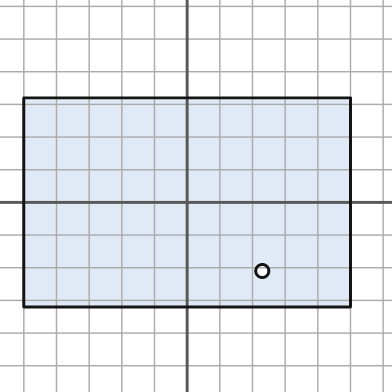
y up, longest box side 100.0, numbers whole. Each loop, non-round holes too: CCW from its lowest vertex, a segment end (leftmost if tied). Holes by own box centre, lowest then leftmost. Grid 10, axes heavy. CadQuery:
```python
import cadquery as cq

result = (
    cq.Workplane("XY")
    .moveTo(-50.0, -32.0)
    .lineTo(50.0, -32.0)
    .lineTo(50.0, 32.0)
    .lineTo(-50.0, 32.0)
    .close()
    .moveTo(23.0, -21.0)
    .circle(2.0)
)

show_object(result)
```